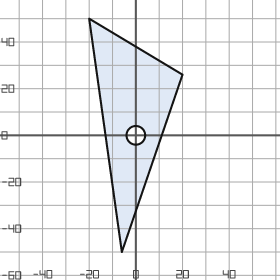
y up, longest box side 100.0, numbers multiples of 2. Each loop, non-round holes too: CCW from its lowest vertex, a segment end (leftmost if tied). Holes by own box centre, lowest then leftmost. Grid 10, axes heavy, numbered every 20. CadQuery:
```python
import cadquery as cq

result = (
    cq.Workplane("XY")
    .moveTo(-6.0, -50.0)
    .lineTo(20.0, 26.0)
    .lineTo(-20.0, 50.0)
    .close()
    .moveTo(0.0, 0.0)
    .circle(4.0)
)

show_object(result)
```